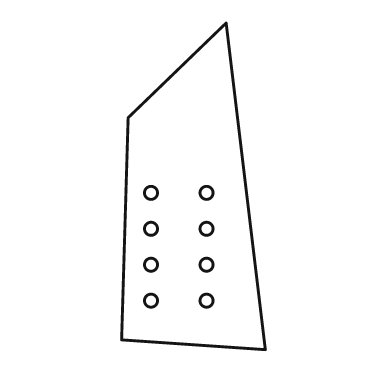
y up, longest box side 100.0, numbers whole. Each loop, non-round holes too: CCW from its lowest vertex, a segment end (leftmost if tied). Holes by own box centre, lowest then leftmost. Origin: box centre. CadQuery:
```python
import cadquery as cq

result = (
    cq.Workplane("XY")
    .moveTo(22.0, -50.0)
    .lineTo(10.0, 50.0)
    .lineTo(-20.0, 21.0)
    .lineTo(-22.0, -47.0)
    .close()
    .moveTo(-13.0, -35.0)
    .circle(2.0)
    .moveTo(4.0, -35.0)
    .circle(2.0)
    .moveTo(-13.0, -24.0)
    .circle(2.0)
    .moveTo(4.0, -24.0)
    .circle(2.0)
    .moveTo(-13.0, -13.0)
    .circle(2.0)
    .moveTo(4.0, -13.0)
    .circle(2.0)
    .moveTo(-13.0, -2.0)
    .circle(2.0)
    .moveTo(4.0, -2.0)
    .circle(2.0)
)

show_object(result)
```